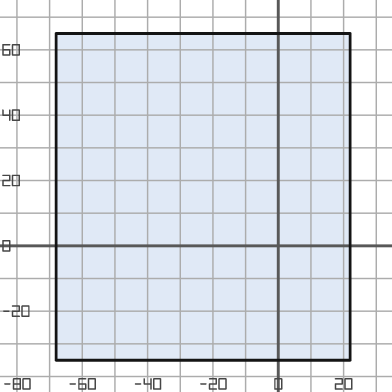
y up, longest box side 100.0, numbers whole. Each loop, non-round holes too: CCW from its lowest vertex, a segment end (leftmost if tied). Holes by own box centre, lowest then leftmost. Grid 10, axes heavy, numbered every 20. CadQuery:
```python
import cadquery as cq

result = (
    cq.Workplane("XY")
    .moveTo(-68.0, -35.0)
    .lineTo(22.0, -35.0)
    .lineTo(22.0, 65.0)
    .lineTo(-68.0, 65.0)
    .close()
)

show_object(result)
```